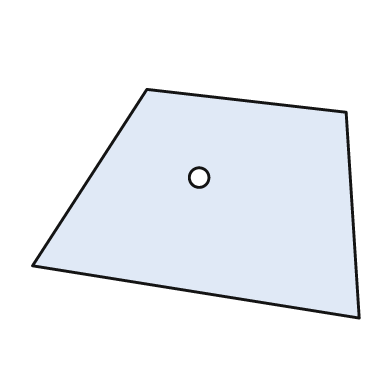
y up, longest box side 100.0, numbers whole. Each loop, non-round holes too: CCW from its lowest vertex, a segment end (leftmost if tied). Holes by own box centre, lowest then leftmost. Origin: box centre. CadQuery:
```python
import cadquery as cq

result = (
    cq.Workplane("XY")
    .moveTo(50.0, -35.0)
    .lineTo(46.0, 28.0)
    .lineTo(-15.0, 35.0)
    .lineTo(-50.0, -19.0)
    .close()
    .moveTo(1.0, 8.0)
    .circle(3.0)
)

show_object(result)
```